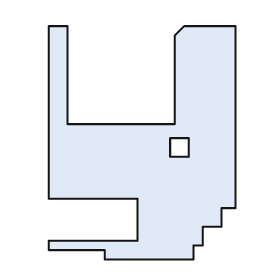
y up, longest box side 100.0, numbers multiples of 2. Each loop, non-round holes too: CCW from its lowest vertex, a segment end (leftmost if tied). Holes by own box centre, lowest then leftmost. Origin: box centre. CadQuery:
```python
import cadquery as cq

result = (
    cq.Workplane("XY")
    .moveTo(-16.0, -50.0)
    .lineTo(22.0, -50.0)
    .lineTo(22.0, -44.0)
    .lineTo(26.0, -44.0)
    .lineTo(26.0, -36.0)
    .lineTo(34.0, -36.0)
    .lineTo(34.0, -28.0)
    .lineTo(40.0, -28.0)
    .lineTo(40.0, 50.0)
    .lineTo(18.0, 50.0)
    .lineTo(14.0, 46.0)
    .lineTo(14.0, 8.0)
    .lineTo(-32.0, 8.0)
    .lineTo(-32.0, 50.0)
    .lineTo(-40.0, 50.0)
    .lineTo(-40.0, -24.0)
    .lineTo(-2.0, -24.0)
    .lineTo(-2.0, -42.0)
    .lineTo(-40.0, -42.0)
    .lineTo(-40.0, -46.0)
    .lineTo(-16.0, -46.0)
    .close()
    .moveTo(12.0, -6.0)
    .lineTo(20.0, -6.0)
    .lineTo(20.0, 2.0)
    .lineTo(12.0, 2.0)
    .close()
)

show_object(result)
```